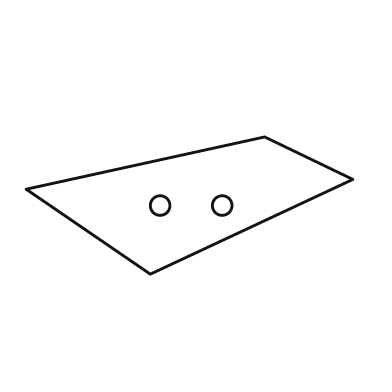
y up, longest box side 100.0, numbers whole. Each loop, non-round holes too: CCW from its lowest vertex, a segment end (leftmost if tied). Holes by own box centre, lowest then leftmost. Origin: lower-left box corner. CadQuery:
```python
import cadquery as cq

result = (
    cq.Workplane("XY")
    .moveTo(38.0, 0.0)
    .lineTo(100.0, 29.0)
    .lineTo(73.0, 42.0)
    .lineTo(0.0, 26.0)
    .close()
    .moveTo(41.0, 21.0)
    .circle(3.0)
    .moveTo(60.0, 21.0)
    .circle(3.0)
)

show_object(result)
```